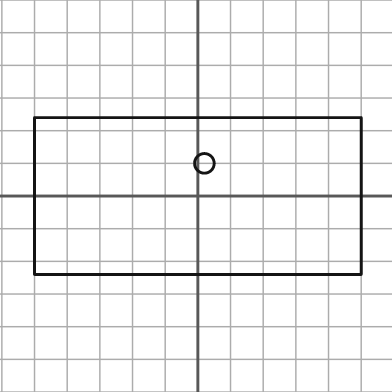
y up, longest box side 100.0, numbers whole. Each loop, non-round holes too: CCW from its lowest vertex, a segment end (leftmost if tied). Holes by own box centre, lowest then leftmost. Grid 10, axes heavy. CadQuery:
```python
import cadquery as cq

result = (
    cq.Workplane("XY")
    .moveTo(-50.0, -24.0)
    .lineTo(50.0, -24.0)
    .lineTo(50.0, 24.0)
    .lineTo(-50.0, 24.0)
    .close()
    .moveTo(2.0, 10.0)
    .circle(3.0)
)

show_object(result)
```